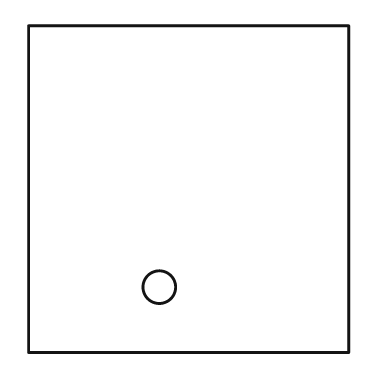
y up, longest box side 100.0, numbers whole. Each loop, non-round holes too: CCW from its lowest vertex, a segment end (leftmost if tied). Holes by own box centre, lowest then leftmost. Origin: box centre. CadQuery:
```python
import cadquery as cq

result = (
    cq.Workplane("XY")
    .moveTo(-49.0, -50.0)
    .lineTo(49.0, -50.0)
    .lineTo(49.0, 50.0)
    .lineTo(-49.0, 50.0)
    .close()
    .moveTo(-9.0, -30.0)
    .circle(5.0)
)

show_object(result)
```